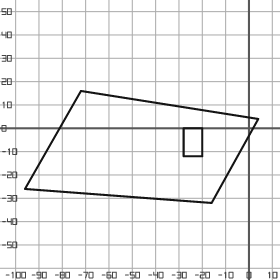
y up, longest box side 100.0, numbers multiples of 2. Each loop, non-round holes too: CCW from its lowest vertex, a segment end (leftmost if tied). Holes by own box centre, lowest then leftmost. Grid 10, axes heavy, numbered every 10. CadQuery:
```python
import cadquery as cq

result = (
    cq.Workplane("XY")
    .moveTo(-16.0, -32.0)
    .lineTo(4.0, 4.0)
    .lineTo(-72.0, 16.0)
    .lineTo(-96.0, -26.0)
    .close()
    .moveTo(-28.0, -12.0)
    .lineTo(-20.0, -12.0)
    .lineTo(-20.0, 0.0)
    .lineTo(-28.0, 0.0)
    .close()
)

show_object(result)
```